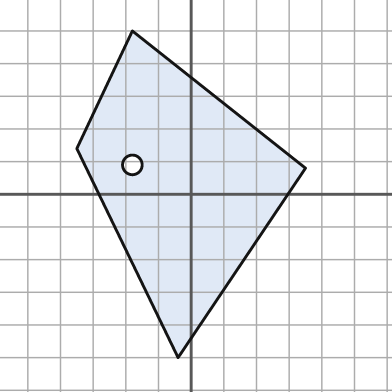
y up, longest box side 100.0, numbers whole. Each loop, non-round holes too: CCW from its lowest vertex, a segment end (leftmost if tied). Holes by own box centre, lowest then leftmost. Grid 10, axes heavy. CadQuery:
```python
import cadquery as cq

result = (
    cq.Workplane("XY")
    .moveTo(-4.0, -50.0)
    .lineTo(35.0, 8.0)
    .lineTo(-18.0, 50.0)
    .lineTo(-35.0, 14.0)
    .close()
    .moveTo(-18.0, 9.0)
    .circle(3.0)
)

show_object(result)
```